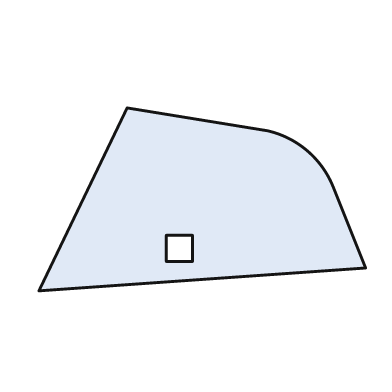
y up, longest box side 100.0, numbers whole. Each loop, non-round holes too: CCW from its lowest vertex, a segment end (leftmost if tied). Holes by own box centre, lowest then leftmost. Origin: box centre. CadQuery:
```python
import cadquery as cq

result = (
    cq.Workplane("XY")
    .moveTo(-50.0, -28.0)
    .lineTo(50.0, -21.0)
    .lineTo(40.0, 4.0)
    .threePointArc((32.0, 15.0), (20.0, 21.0))
    .lineTo(-23.0, 28.0)
    .close()
    .moveTo(-11.0, -19.0)
    .lineTo(-3.0, -19.0)
    .lineTo(-3.0, -11.0)
    .lineTo(-11.0, -11.0)
    .close()
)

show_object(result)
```